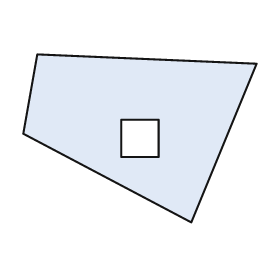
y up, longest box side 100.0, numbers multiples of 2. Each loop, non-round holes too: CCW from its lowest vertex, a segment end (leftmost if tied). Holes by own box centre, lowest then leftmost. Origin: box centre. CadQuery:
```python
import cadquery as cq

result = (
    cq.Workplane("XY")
    .moveTo(22.0, -36.0)
    .lineTo(50.0, 32.0)
    .lineTo(-44.0, 36.0)
    .lineTo(-50.0, 2.0)
    .close()
    .moveTo(-8.0, -8.0)
    .lineTo(8.0, -8.0)
    .lineTo(8.0, 8.0)
    .lineTo(-8.0, 8.0)
    .close()
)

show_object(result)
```